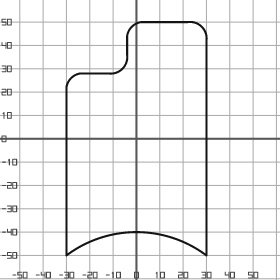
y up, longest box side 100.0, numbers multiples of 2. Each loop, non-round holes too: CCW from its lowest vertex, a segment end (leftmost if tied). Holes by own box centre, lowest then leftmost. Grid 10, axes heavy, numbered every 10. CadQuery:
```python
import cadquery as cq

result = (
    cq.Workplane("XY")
    .moveTo(-30.0, -50.0)
    .threePointArc((0.0, -40.0), (30.0, -50.0))
    .lineTo(30.0, 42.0)
    .threePointArc((28.0, 48.0), (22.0, 50.0))
    .lineTo(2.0, 50.0)
    .threePointArc((-2.0, 48.0), (-4.0, 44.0))
    .lineTo(-4.0, 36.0)
    .threePointArc((-6.0, 30.0), (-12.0, 28.0))
    .lineTo(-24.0, 28.0)
    .threePointArc((-28.0, 26.0), (-30.0, 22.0))
    .close()
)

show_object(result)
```